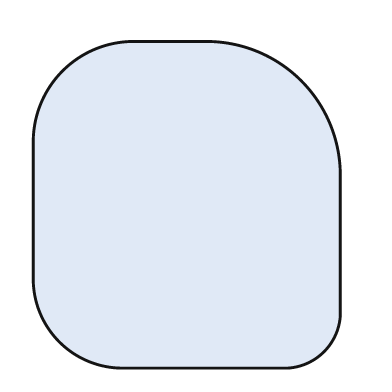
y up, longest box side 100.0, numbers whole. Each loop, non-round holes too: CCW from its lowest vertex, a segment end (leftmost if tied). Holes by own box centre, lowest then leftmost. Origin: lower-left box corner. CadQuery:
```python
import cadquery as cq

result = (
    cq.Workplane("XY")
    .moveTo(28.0, 0.0)
    .lineTo(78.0, 0.0)
    .threePointArc((89.0, 5.0), (94.0, 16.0))
    .lineTo(94.0, 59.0)
    .threePointArc((82.0, 88.0), (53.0, 100.0))
    .lineTo(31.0, 100.0)
    .threePointArc((9.0, 91.0), (0.0, 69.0))
    .lineTo(0.0, 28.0)
    .threePointArc((8.0, 8.0), (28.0, 0.0))
    .close()
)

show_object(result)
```